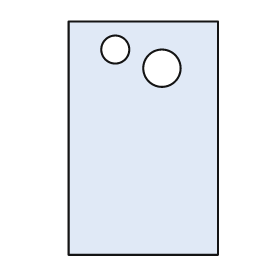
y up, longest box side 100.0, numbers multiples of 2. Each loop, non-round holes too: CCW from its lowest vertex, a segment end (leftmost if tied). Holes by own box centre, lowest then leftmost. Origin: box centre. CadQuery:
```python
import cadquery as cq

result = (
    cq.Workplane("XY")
    .moveTo(-32.0, -50.0)
    .lineTo(32.0, -50.0)
    .lineTo(32.0, 50.0)
    .lineTo(-32.0, 50.0)
    .close()
    .moveTo(8.0, 30.0)
    .circle(8.0)
    .moveTo(-12.0, 38.0)
    .circle(6.0)
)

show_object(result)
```